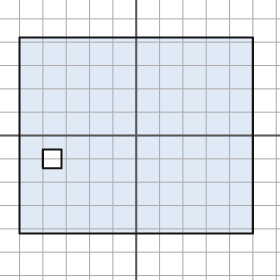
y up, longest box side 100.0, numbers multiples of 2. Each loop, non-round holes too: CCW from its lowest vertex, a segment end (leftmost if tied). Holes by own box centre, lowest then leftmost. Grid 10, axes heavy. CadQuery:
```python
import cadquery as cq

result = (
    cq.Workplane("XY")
    .moveTo(-50.0, -42.0)
    .lineTo(50.0, -42.0)
    .lineTo(50.0, 42.0)
    .lineTo(-50.0, 42.0)
    .close()
    .moveTo(-40.0, -14.0)
    .lineTo(-32.0, -14.0)
    .lineTo(-32.0, -6.0)
    .lineTo(-40.0, -6.0)
    .close()
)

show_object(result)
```